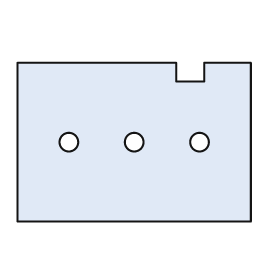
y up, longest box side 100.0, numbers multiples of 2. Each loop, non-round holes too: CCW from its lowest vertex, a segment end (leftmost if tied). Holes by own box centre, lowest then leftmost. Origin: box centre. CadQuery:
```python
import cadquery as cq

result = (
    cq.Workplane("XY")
    .moveTo(-50.0, -34.0)
    .lineTo(50.0, -34.0)
    .lineTo(50.0, 34.0)
    .lineTo(30.0, 34.0)
    .lineTo(30.0, 26.0)
    .lineTo(18.0, 26.0)
    .lineTo(18.0, 34.0)
    .lineTo(-50.0, 34.0)
    .close()
    .moveTo(-28.0, 0.0)
    .circle(4.0)
    .moveTo(0.0, 0.0)
    .circle(4.0)
    .moveTo(28.0, 0.0)
    .circle(4.0)
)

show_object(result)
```